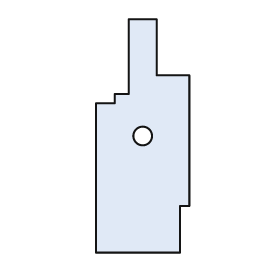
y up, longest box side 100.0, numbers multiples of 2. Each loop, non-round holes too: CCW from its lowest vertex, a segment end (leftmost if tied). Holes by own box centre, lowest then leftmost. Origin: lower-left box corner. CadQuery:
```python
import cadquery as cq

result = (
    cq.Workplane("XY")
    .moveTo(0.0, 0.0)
    .lineTo(36.0, 0.0)
    .lineTo(36.0, 20.0)
    .lineTo(40.0, 20.0)
    .lineTo(40.0, 76.0)
    .lineTo(26.0, 76.0)
    .lineTo(26.0, 100.0)
    .lineTo(14.0, 100.0)
    .lineTo(14.0, 68.0)
    .lineTo(8.0, 68.0)
    .lineTo(8.0, 64.0)
    .lineTo(0.0, 64.0)
    .close()
    .moveTo(20.0, 50.0)
    .circle(4.0)
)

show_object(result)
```